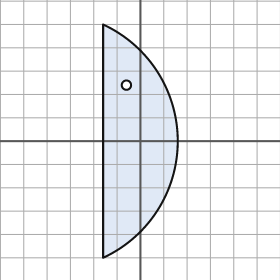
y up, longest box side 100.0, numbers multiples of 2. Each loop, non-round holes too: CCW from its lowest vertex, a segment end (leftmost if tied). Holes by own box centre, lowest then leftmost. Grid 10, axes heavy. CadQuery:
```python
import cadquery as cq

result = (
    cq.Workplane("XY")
    .moveTo(-16.0, -50.0)
    .threePointArc((16.0, 0.0), (-16.0, 50.0))
    .close()
    .moveTo(-6.0, 24.0)
    .circle(2.0)
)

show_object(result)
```